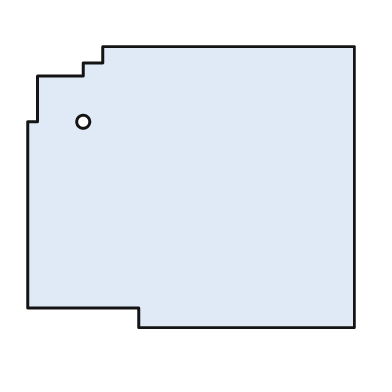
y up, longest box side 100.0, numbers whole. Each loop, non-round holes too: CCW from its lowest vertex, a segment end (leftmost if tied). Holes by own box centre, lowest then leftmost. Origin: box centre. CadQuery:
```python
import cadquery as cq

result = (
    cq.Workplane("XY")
    .moveTo(-16.0, -43.0)
    .lineTo(50.0, -43.0)
    .lineTo(50.0, 43.0)
    .lineTo(-27.0, 43.0)
    .lineTo(-27.0, 38.0)
    .lineTo(-33.0, 38.0)
    .lineTo(-33.0, 34.0)
    .lineTo(-47.0, 34.0)
    .lineTo(-47.0, 20.0)
    .lineTo(-50.0, 20.0)
    .lineTo(-50.0, -37.0)
    .lineTo(-16.0, -37.0)
    .close()
    .moveTo(-33.0, 20.0)
    .circle(2.0)
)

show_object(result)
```